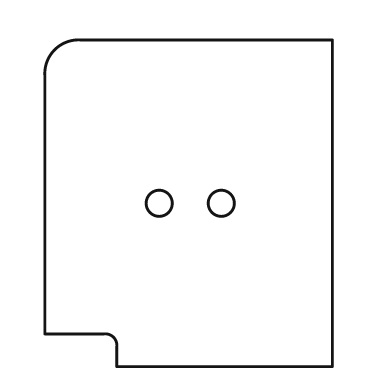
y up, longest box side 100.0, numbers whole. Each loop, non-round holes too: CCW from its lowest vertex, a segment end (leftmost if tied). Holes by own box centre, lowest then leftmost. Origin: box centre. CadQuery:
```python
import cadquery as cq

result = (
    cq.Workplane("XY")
    .moveTo(-22.0, -50.0)
    .lineTo(44.0, -50.0)
    .lineTo(44.0, 50.0)
    .lineTo(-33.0, 50.0)
    .threePointArc((-41.0, 47.0), (-44.0, 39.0))
    .lineTo(-44.0, -40.0)
    .lineTo(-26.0, -40.0)
    .threePointArc((-23.0, -41.0), (-22.0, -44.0))
    .close()
    .moveTo(-9.0, 0.0)
    .circle(4.0)
    .moveTo(10.0, 0.0)
    .circle(4.0)
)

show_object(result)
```